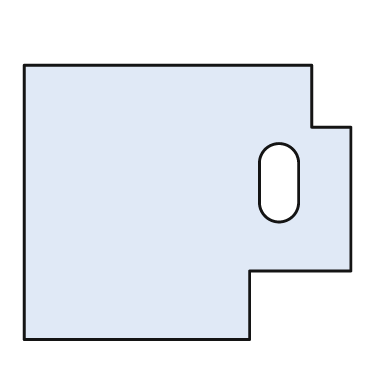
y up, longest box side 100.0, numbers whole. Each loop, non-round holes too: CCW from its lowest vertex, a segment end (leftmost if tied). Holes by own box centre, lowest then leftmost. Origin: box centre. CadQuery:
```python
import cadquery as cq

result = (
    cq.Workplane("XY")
    .moveTo(-50.0, -42.0)
    .lineTo(19.0, -42.0)
    .lineTo(19.0, -21.0)
    .lineTo(50.0, -21.0)
    .lineTo(50.0, 23.0)
    .lineTo(38.0, 23.0)
    .lineTo(38.0, 42.0)
    .lineTo(-50.0, 42.0)
    .close()
    .moveTo(22.0, 0.0)
    .threePointArc((28.0, -6.0), (34.0, 0.0))
    .lineTo(34.0, 12.0)
    .threePointArc((28.0, 18.0), (22.0, 12.0))
    .close()
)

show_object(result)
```